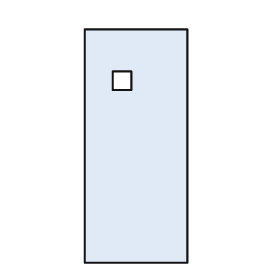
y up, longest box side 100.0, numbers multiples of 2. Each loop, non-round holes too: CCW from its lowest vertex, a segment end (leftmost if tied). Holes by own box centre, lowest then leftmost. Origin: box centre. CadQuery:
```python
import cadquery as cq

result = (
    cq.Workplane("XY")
    .moveTo(-22.0, -50.0)
    .lineTo(22.0, -50.0)
    .lineTo(22.0, 50.0)
    .lineTo(-22.0, 50.0)
    .close()
    .moveTo(-10.0, 24.0)
    .lineTo(-2.0, 24.0)
    .lineTo(-2.0, 32.0)
    .lineTo(-10.0, 32.0)
    .close()
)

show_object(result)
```